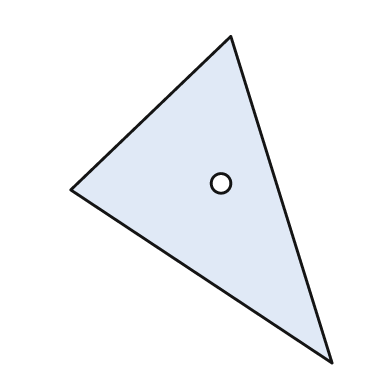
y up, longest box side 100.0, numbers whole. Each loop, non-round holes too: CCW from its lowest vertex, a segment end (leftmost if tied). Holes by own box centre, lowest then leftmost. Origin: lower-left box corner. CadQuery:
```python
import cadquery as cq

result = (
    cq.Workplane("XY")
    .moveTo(80.0, 0.0)
    .lineTo(49.0, 100.0)
    .lineTo(0.0, 53.0)
    .close()
    .moveTo(46.0, 55.0)
    .circle(3.0)
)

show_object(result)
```